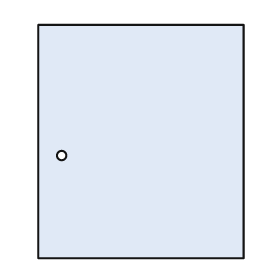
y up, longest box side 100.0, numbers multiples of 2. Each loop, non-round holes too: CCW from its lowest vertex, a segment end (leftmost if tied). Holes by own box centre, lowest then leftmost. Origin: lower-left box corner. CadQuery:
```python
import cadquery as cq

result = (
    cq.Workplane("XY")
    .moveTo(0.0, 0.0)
    .lineTo(88.0, 0.0)
    .lineTo(88.0, 100.0)
    .lineTo(0.0, 100.0)
    .close()
    .moveTo(10.0, 44.0)
    .circle(2.0)
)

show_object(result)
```